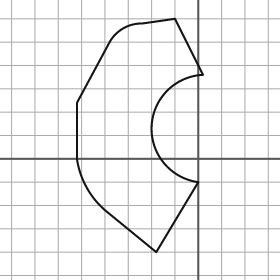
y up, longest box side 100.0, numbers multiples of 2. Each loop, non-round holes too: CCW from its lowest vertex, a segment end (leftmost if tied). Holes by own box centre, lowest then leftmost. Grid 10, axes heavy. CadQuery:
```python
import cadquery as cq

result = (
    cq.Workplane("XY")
    .moveTo(-18.0, -40.0)
    .lineTo(0.0, -10.0)
    .threePointArc((-20.0, 14.0), (2.0, 36.0))
    .lineTo(-10.0, 60.0)
    .lineTo(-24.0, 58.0)
    .threePointArc((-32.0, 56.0), (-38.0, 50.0))
    .lineTo(-52.0, 24.0)
    .lineTo(-52.0, 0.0)
    .threePointArc((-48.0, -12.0), (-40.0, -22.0))
    .close()
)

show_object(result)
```